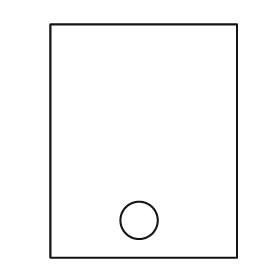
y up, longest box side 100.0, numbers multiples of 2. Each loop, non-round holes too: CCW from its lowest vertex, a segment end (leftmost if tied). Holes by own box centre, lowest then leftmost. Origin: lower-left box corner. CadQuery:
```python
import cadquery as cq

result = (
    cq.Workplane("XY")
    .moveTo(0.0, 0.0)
    .lineTo(80.0, 0.0)
    .lineTo(80.0, 100.0)
    .lineTo(0.0, 100.0)
    .close()
    .moveTo(38.0, 16.0)
    .circle(8.0)
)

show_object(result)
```